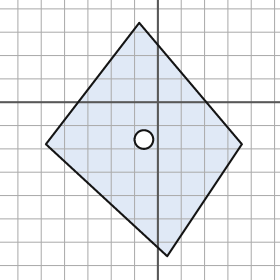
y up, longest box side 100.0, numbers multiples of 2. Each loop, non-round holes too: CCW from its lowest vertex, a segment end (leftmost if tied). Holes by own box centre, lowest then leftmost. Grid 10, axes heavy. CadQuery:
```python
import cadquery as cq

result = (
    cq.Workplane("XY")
    .moveTo(4.0, -66.0)
    .lineTo(36.0, -18.0)
    .lineTo(-8.0, 34.0)
    .lineTo(-48.0, -18.0)
    .close()
    .moveTo(-6.0, -16.0)
    .circle(4.0)
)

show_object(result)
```